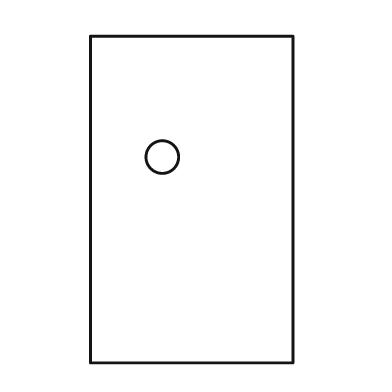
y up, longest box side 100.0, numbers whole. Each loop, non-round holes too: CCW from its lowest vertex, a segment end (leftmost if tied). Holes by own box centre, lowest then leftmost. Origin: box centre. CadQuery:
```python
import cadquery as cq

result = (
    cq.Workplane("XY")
    .moveTo(-31.0, -50.0)
    .lineTo(31.0, -50.0)
    .lineTo(31.0, 50.0)
    .lineTo(-31.0, 50.0)
    .close()
    .moveTo(-9.0, 13.0)
    .circle(5.0)
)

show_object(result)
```